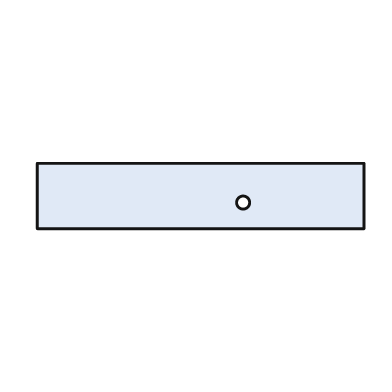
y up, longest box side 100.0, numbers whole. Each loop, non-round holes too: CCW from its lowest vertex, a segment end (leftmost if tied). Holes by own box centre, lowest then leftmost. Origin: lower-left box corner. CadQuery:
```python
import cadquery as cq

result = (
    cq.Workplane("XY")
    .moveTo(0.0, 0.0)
    .lineTo(100.0, 0.0)
    .lineTo(100.0, 20.0)
    .lineTo(0.0, 20.0)
    .close()
    .moveTo(63.0, 8.0)
    .circle(2.0)
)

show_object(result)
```